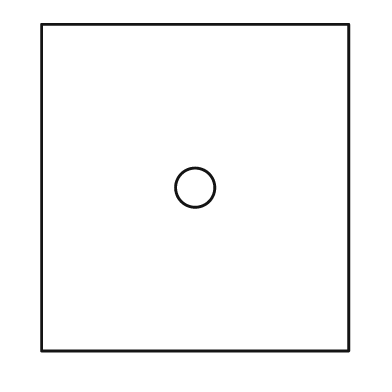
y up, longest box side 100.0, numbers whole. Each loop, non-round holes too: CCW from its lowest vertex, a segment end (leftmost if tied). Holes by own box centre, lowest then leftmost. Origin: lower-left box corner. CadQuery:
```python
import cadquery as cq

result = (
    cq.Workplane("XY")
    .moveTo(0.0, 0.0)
    .lineTo(94.0, 0.0)
    .lineTo(94.0, 100.0)
    .lineTo(0.0, 100.0)
    .close()
    .moveTo(47.0, 50.0)
    .circle(6.0)
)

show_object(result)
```